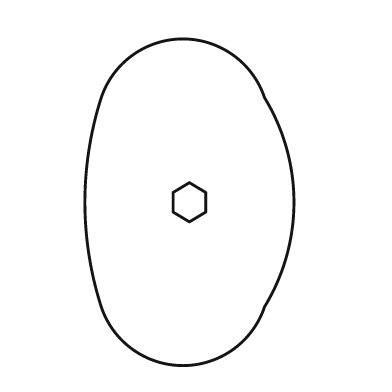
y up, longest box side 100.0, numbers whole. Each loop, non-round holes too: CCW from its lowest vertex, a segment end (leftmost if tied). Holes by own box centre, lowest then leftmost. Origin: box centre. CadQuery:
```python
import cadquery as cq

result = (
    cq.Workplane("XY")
    .moveTo(-27.0, -32.0)
    .threePointArc((-2.0, -50.0), (23.0, -32.0))
    .threePointArc((32.0, 0.0), (23.0, 32.0))
    .threePointArc((-2.0, 50.0), (-27.0, 32.0))
    .threePointArc((-32.0, 0.0), (-27.0, -32.0))
    .close()
    .moveTo(0.0, -6.0)
    .lineTo(5.0, -3.0)
    .lineTo(5.0, 3.0)
    .lineTo(0.0, 6.0)
    .lineTo(-5.0, 3.0)
    .lineTo(-5.0, -3.0)
    .close()
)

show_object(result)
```